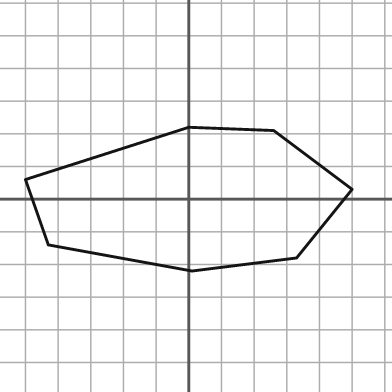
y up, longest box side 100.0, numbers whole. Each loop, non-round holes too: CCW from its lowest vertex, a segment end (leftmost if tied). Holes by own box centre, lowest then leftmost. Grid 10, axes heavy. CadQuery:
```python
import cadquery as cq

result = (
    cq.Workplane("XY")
    .moveTo(1.0, -22.0)
    .lineTo(33.0, -18.0)
    .lineTo(50.0, 3.0)
    .lineTo(26.0, 21.0)
    .lineTo(0.0, 22.0)
    .lineTo(-50.0, 6.0)
    .lineTo(-43.0, -14.0)
    .close()
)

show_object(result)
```